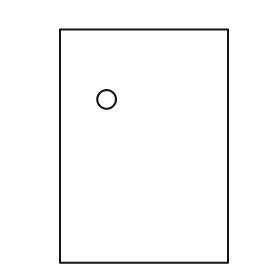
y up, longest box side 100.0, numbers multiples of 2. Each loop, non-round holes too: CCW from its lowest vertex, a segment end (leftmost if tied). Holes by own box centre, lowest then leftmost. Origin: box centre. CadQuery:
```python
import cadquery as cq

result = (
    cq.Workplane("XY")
    .moveTo(-36.0, -50.0)
    .lineTo(36.0, -50.0)
    .lineTo(36.0, 50.0)
    .lineTo(-36.0, 50.0)
    .close()
    .moveTo(-16.0, 20.0)
    .circle(4.0)
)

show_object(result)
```